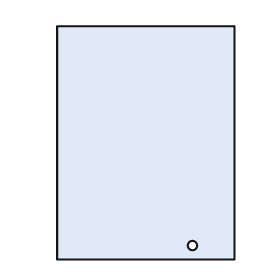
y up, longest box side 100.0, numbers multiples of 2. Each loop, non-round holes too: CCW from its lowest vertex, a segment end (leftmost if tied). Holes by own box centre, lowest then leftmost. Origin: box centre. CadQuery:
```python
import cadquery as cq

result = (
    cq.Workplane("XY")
    .moveTo(-38.0, -50.0)
    .lineTo(38.0, -50.0)
    .lineTo(38.0, 50.0)
    .lineTo(-38.0, 50.0)
    .close()
    .moveTo(20.0, -44.0)
    .circle(2.0)
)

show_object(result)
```